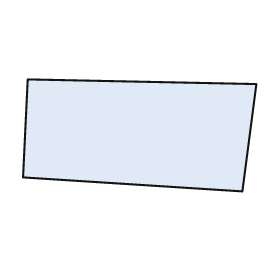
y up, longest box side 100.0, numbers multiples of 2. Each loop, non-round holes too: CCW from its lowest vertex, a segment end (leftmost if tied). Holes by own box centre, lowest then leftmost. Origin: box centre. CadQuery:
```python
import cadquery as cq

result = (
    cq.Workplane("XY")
    .moveTo(44.0, -24.0)
    .lineTo(50.0, 22.0)
    .lineTo(-48.0, 24.0)
    .lineTo(-50.0, -18.0)
    .close()
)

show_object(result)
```